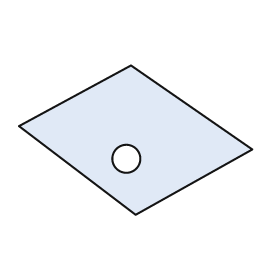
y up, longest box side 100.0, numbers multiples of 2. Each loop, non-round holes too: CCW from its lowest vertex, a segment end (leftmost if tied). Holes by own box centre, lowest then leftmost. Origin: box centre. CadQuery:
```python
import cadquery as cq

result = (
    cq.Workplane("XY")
    .moveTo(0.0, -32.0)
    .lineTo(50.0, -4.0)
    .lineTo(-2.0, 32.0)
    .lineTo(-50.0, 6.0)
    .close()
    .moveTo(-4.0, -8.0)
    .circle(6.0)
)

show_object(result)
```